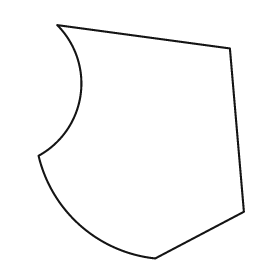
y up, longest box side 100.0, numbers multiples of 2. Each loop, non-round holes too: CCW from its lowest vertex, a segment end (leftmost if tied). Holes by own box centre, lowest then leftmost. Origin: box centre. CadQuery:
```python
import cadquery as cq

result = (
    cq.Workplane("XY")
    .moveTo(6.0, -50.0)
    .lineTo(44.0, -30.0)
    .lineTo(38.0, 40.0)
    .lineTo(-36.0, 50.0)
    .threePointArc((-26.0, 20.0), (-44.0, -6.0))
    .threePointArc((-26.0, -36.0), (6.0, -50.0))
    .close()
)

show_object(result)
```